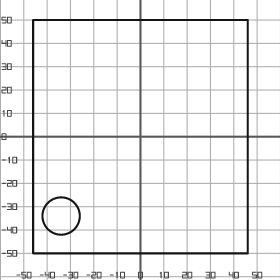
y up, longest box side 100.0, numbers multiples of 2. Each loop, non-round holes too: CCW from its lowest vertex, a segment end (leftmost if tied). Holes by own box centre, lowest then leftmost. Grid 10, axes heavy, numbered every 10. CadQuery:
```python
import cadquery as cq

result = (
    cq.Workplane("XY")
    .moveTo(-46.0, -50.0)
    .lineTo(46.0, -50.0)
    .lineTo(46.0, 50.0)
    .lineTo(-46.0, 50.0)
    .close()
    .moveTo(-34.0, -34.0)
    .circle(8.0)
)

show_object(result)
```